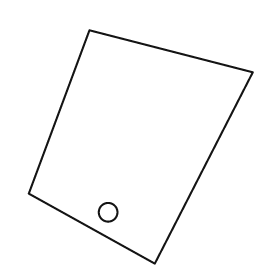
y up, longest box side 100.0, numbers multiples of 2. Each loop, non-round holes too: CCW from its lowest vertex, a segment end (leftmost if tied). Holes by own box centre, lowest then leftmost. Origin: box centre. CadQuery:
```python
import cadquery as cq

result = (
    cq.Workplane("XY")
    .moveTo(6.0, -50.0)
    .lineTo(48.0, 32.0)
    .lineTo(-22.0, 50.0)
    .lineTo(-48.0, -20.0)
    .close()
    .moveTo(-14.0, -28.0)
    .circle(4.0)
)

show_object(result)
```